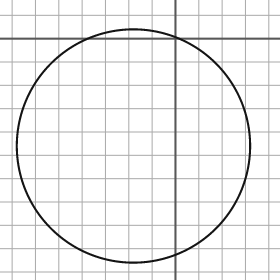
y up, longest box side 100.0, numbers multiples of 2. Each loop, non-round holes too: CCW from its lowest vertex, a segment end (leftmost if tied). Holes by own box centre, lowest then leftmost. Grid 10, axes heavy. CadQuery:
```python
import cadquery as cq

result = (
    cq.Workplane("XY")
    .moveTo(-18.0, -46.0)
    .circle(50.0)
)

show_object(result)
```